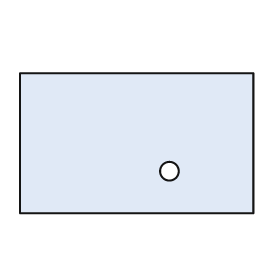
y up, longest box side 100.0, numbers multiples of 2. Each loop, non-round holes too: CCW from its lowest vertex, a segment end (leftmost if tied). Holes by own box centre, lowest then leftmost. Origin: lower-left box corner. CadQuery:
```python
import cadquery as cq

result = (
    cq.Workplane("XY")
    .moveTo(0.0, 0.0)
    .lineTo(100.0, 0.0)
    .lineTo(100.0, 60.0)
    .lineTo(0.0, 60.0)
    .close()
    .moveTo(64.0, 18.0)
    .circle(4.0)
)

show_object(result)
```